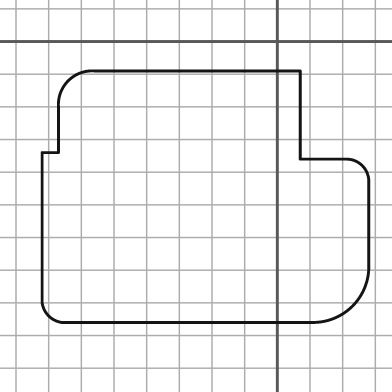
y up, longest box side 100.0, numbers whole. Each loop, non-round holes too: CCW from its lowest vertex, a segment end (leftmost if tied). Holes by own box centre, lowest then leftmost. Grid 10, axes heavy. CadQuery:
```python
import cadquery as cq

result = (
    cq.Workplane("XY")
    .moveTo(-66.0, -86.0)
    .lineTo(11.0, -86.0)
    .threePointArc((23.0, -81.0), (28.0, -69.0))
    .lineTo(28.0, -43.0)
    .threePointArc((26.0, -38.0), (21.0, -36.0))
    .lineTo(7.0, -36.0)
    .lineTo(7.0, -9.0)
    .lineTo(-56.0, -9.0)
    .threePointArc((-64.0, -12.0), (-67.0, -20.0))
    .lineTo(-67.0, -34.0)
    .lineTo(-72.0, -34.0)
    .lineTo(-72.0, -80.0)
    .threePointArc((-70.0, -84.0), (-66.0, -86.0))
    .close()
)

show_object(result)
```